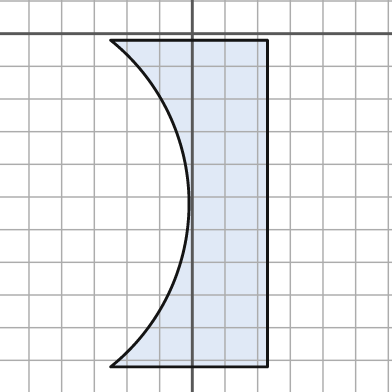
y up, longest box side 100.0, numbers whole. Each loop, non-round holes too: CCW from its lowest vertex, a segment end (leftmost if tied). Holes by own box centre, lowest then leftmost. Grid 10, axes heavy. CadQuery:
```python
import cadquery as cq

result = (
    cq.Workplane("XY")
    .moveTo(-25.0, -102.0)
    .lineTo(23.0, -102.0)
    .lineTo(23.0, -2.0)
    .lineTo(-25.0, -2.0)
    .threePointArc((-1.0, -52.0), (-25.0, -102.0))
    .close()
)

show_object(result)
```